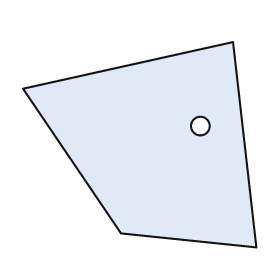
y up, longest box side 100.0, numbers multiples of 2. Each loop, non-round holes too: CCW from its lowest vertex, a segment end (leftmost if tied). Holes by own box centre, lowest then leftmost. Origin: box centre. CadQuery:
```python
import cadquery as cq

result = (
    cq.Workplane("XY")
    .moveTo(50.0, -44.0)
    .lineTo(40.0, 44.0)
    .lineTo(-50.0, 24.0)
    .lineTo(-8.0, -38.0)
    .close()
    .moveTo(26.0, 8.0)
    .circle(4.0)
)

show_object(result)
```